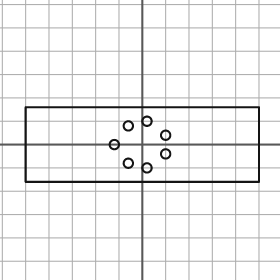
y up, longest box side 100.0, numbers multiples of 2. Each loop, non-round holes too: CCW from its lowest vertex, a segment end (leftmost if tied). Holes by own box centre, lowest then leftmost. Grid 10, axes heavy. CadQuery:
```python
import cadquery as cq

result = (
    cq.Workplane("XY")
    .moveTo(-50.0, -16.0)
    .lineTo(50.0, -16.0)
    .lineTo(50.0, 16.0)
    .lineTo(-50.0, 16.0)
    .close()
    .moveTo(2.0, -10.0)
    .circle(2.0)
    .moveTo(-6.0, -8.0)
    .circle(2.0)
    .moveTo(10.0, -4.0)
    .circle(2.0)
    .moveTo(-12.0, 0.0)
    .circle(2.0)
    .moveTo(10.0, 4.0)
    .circle(2.0)
    .moveTo(-6.0, 8.0)
    .circle(2.0)
    .moveTo(2.0, 10.0)
    .circle(2.0)
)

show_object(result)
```